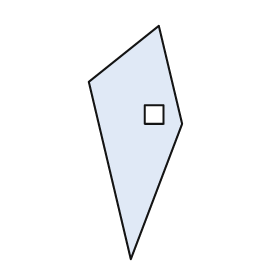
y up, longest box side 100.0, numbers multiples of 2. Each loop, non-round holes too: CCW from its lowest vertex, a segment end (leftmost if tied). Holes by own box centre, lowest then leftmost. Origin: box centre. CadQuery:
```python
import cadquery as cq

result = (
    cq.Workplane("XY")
    .moveTo(-2.0, -50.0)
    .lineTo(20.0, 8.0)
    .lineTo(10.0, 50.0)
    .lineTo(-20.0, 26.0)
    .close()
    .moveTo(4.0, 8.0)
    .lineTo(12.0, 8.0)
    .lineTo(12.0, 16.0)
    .lineTo(4.0, 16.0)
    .close()
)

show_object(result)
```